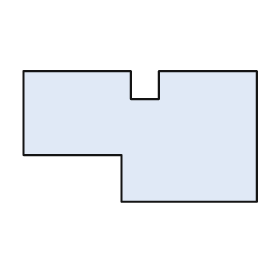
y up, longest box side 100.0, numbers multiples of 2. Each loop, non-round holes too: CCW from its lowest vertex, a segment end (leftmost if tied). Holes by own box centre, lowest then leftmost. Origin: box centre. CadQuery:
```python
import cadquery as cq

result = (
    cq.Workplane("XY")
    .moveTo(-8.0, -28.0)
    .lineTo(50.0, -28.0)
    .lineTo(50.0, 28.0)
    .lineTo(8.0, 28.0)
    .lineTo(8.0, 16.0)
    .lineTo(-4.0, 16.0)
    .lineTo(-4.0, 28.0)
    .lineTo(-50.0, 28.0)
    .lineTo(-50.0, -8.0)
    .lineTo(-8.0, -8.0)
    .close()
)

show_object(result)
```